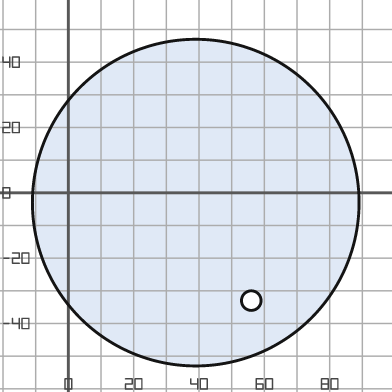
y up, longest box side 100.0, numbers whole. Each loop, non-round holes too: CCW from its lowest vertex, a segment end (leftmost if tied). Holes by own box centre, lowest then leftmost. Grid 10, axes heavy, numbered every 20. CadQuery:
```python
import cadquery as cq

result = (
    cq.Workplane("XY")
    .moveTo(39.0, -3.0)
    .circle(50.0)
    .moveTo(56.0, -33.0)
    .circle(3.0)
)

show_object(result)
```